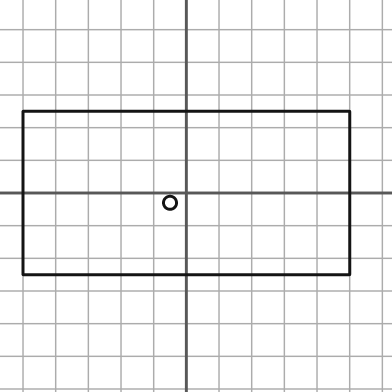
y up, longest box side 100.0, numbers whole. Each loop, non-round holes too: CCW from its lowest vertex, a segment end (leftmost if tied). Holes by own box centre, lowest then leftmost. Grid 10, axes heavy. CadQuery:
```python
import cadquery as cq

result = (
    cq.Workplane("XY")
    .moveTo(-50.0, -25.0)
    .lineTo(50.0, -25.0)
    .lineTo(50.0, 25.0)
    .lineTo(-50.0, 25.0)
    .close()
    .moveTo(-5.0, -3.0)
    .circle(2.0)
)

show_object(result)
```